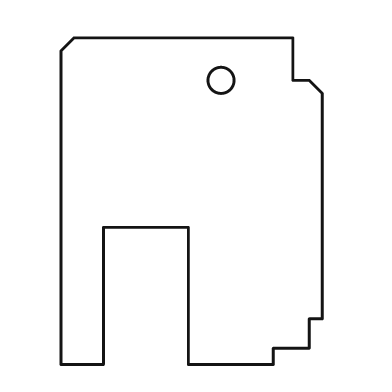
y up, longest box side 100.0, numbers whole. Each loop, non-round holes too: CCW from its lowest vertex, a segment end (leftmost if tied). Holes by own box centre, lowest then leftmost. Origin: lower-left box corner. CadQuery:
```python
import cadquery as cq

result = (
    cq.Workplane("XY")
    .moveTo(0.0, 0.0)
    .lineTo(13.0, 0.0)
    .lineTo(13.0, 42.0)
    .lineTo(39.0, 42.0)
    .lineTo(39.0, 0.0)
    .lineTo(65.0, 0.0)
    .lineTo(65.0, 5.0)
    .lineTo(76.0, 5.0)
    .lineTo(76.0, 14.0)
    .lineTo(80.0, 14.0)
    .lineTo(80.0, 83.0)
    .lineTo(76.0, 87.0)
    .lineTo(71.0, 87.0)
    .lineTo(71.0, 100.0)
    .lineTo(4.0, 100.0)
    .lineTo(0.0, 96.0)
    .close()
    .moveTo(49.0, 87.0)
    .circle(4.0)
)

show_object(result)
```